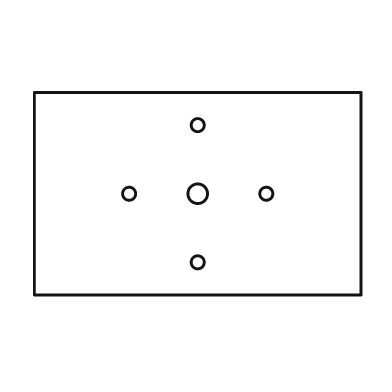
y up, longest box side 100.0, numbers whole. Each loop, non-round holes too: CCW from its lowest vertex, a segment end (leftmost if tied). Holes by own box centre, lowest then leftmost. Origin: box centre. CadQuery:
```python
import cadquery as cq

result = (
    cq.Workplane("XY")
    .moveTo(-50.0, -31.0)
    .lineTo(50.0, -31.0)
    .lineTo(50.0, 31.0)
    .lineTo(-50.0, 31.0)
    .close()
    .moveTo(0.0, -21.0)
    .circle(2.0)
    .moveTo(-21.0, 0.0)
    .circle(2.0)
    .moveTo(0.0, 0.0)
    .circle(3.0)
    .moveTo(21.0, 0.0)
    .circle(2.0)
    .moveTo(0.0, 21.0)
    .circle(2.0)
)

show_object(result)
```